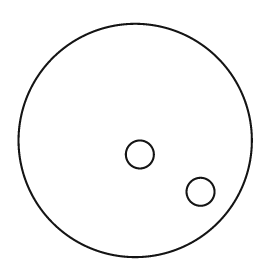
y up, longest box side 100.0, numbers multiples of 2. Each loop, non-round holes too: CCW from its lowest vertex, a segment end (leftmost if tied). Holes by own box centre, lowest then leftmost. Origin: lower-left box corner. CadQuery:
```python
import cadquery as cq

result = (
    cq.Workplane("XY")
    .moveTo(50.0, 50.0)
    .circle(50.0)
    .moveTo(78.0, 28.0)
    .circle(6.0)
    .moveTo(52.0, 44.0)
    .circle(6.0)
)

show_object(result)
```